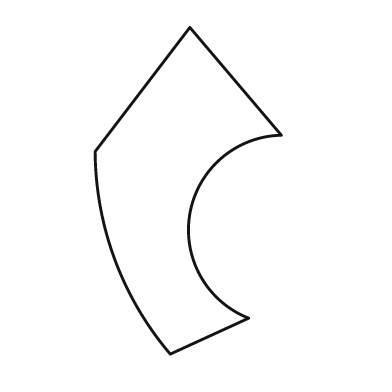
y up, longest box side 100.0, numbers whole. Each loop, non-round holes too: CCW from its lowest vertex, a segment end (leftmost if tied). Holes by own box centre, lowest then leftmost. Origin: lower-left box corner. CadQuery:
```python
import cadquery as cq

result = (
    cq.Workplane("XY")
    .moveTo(23.0, 0.0)
    .lineTo(47.0, 11.0)
    .threePointArc((29.0, 43.0), (57.0, 67.0))
    .lineTo(29.0, 100.0)
    .lineTo(0.0, 62.0)
    .threePointArc((6.0, 29.0), (23.0, 0.0))
    .close()
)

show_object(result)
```